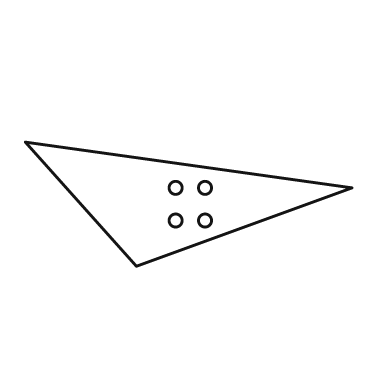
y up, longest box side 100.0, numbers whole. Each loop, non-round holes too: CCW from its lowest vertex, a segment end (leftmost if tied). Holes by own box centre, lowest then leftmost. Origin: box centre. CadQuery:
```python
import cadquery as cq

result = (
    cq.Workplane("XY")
    .moveTo(-16.0, -19.0)
    .lineTo(50.0, 5.0)
    .lineTo(-50.0, 19.0)
    .close()
    .moveTo(-4.0, -5.0)
    .circle(2.0)
    .moveTo(5.0, -5.0)
    .circle(2.0)
    .moveTo(-4.0, 5.0)
    .circle(2.0)
    .moveTo(5.0, 5.0)
    .circle(2.0)
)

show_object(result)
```